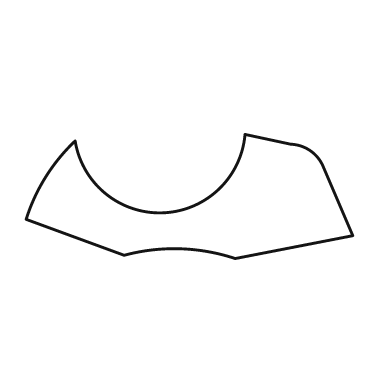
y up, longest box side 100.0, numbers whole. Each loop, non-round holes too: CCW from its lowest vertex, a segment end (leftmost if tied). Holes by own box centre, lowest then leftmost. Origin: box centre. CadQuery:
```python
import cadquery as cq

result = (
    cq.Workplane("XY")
    .moveTo(14.0, -19.0)
    .lineTo(50.0, -12.0)
    .lineTo(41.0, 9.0)
    .threePointArc((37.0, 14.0), (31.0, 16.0))
    .lineTo(17.0, 19.0)
    .threePointArc((-8.0, -5.0), (-35.0, 17.0))
    .threePointArc((-44.0, 6.0), (-50.0, -7.0))
    .lineTo(-20.0, -18.0)
    .threePointArc((-3.0, -16.0), (14.0, -19.0))
    .close()
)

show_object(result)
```